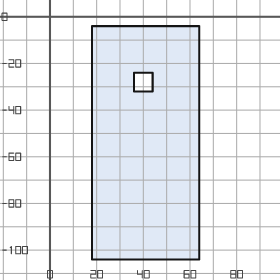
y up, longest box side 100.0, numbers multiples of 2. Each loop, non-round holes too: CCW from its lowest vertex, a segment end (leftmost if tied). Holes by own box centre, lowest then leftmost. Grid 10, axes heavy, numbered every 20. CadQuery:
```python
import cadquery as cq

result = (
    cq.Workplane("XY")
    .moveTo(18.0, -104.0)
    .lineTo(64.0, -104.0)
    .lineTo(64.0, -4.0)
    .lineTo(18.0, -4.0)
    .close()
    .moveTo(36.0, -32.0)
    .lineTo(44.0, -32.0)
    .lineTo(44.0, -24.0)
    .lineTo(36.0, -24.0)
    .close()
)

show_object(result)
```